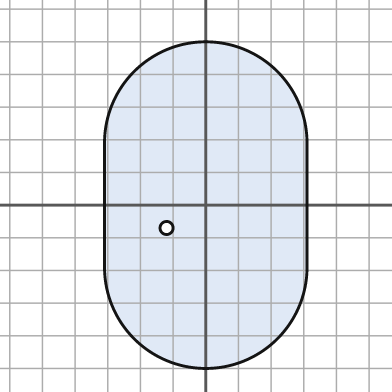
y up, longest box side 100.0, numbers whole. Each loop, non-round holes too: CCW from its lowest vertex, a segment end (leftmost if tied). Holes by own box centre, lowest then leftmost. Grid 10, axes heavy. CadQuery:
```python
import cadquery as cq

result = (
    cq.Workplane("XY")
    .moveTo(-31.0, -19.0)
    .threePointArc((0.0, -50.0), (31.0, -19.0))
    .lineTo(31.0, 19.0)
    .threePointArc((0.0, 50.0), (-31.0, 19.0))
    .close()
    .moveTo(-12.0, -7.0)
    .circle(2.0)
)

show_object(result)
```